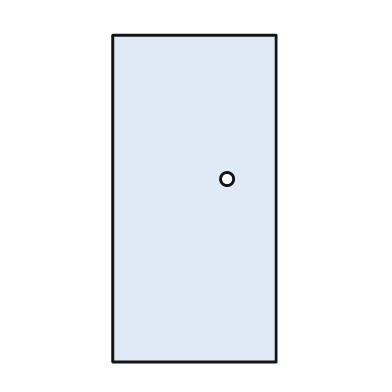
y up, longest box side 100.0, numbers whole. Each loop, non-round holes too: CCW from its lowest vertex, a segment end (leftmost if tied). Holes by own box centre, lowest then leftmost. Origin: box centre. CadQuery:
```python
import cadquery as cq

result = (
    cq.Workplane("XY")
    .moveTo(-25.0, -50.0)
    .lineTo(25.0, -50.0)
    .lineTo(25.0, 50.0)
    .lineTo(-25.0, 50.0)
    .close()
    .moveTo(10.0, 6.0)
    .circle(2.0)
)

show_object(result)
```